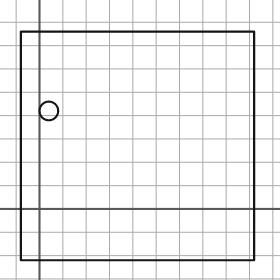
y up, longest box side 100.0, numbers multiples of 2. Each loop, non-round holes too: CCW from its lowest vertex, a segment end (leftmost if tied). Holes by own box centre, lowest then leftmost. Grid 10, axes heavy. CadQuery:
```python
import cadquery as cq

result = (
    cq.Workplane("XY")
    .moveTo(-8.0, -22.0)
    .lineTo(92.0, -22.0)
    .lineTo(92.0, 76.0)
    .lineTo(-8.0, 76.0)
    .close()
    .moveTo(4.0, 42.0)
    .circle(4.0)
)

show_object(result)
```